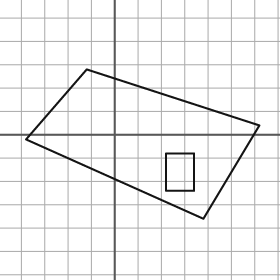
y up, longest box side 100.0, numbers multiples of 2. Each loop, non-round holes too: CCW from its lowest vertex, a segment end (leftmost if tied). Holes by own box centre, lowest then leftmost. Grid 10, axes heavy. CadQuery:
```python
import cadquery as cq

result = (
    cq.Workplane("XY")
    .moveTo(38.0, -36.0)
    .lineTo(62.0, 4.0)
    .lineTo(-12.0, 28.0)
    .lineTo(-38.0, -2.0)
    .close()
    .moveTo(22.0, -24.0)
    .lineTo(34.0, -24.0)
    .lineTo(34.0, -8.0)
    .lineTo(22.0, -8.0)
    .close()
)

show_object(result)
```